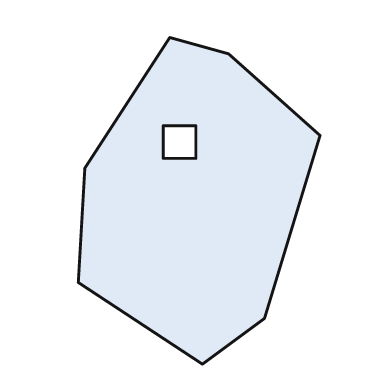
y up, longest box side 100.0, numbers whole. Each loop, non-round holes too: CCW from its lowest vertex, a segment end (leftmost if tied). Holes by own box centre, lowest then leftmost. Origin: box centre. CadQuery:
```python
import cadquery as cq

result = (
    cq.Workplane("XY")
    .moveTo(1.0, -50.0)
    .lineTo(20.0, -36.0)
    .lineTo(37.0, 20.0)
    .lineTo(9.0, 45.0)
    .lineTo(-9.0, 50.0)
    .lineTo(-35.0, 10.0)
    .lineTo(-37.0, -25.0)
    .close()
    .moveTo(-11.0, 13.0)
    .lineTo(-1.0, 13.0)
    .lineTo(-1.0, 23.0)
    .lineTo(-11.0, 23.0)
    .close()
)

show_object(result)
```